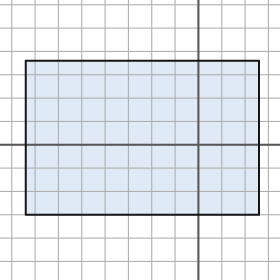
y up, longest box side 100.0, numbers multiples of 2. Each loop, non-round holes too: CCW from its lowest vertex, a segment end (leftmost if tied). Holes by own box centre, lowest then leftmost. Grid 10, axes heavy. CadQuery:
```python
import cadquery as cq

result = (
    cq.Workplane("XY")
    .moveTo(-74.0, -30.0)
    .lineTo(26.0, -30.0)
    .lineTo(26.0, 36.0)
    .lineTo(-74.0, 36.0)
    .close()
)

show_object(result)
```